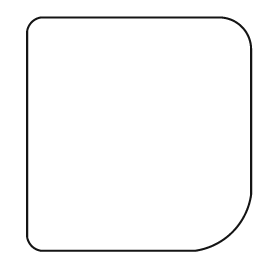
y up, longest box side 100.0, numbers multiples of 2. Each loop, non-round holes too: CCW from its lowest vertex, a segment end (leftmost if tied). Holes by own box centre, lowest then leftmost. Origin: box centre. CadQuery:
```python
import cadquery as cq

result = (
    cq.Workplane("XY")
    .moveTo(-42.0, -50.0)
    .lineTo(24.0, -50.0)
    .threePointArc((40.0, -42.0), (48.0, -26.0))
    .lineTo(48.0, 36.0)
    .threePointArc((44.0, 46.0), (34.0, 50.0))
    .lineTo(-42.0, 50.0)
    .threePointArc((-46.0, 48.0), (-48.0, 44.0))
    .lineTo(-48.0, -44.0)
    .threePointArc((-46.0, -48.0), (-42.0, -50.0))
    .close()
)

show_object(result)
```